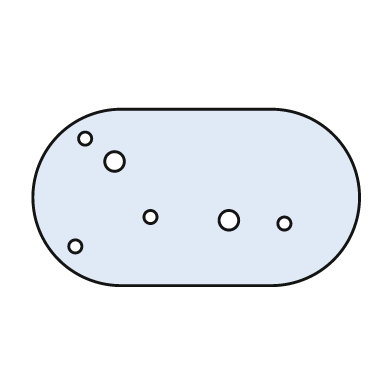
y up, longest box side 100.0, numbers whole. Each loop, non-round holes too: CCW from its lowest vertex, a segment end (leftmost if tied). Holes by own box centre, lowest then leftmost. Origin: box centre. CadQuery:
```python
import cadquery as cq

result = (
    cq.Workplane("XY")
    .moveTo(-23.0, -27.0)
    .lineTo(23.0, -27.0)
    .threePointArc((50.0, 0.0), (23.0, 27.0))
    .lineTo(-23.0, 27.0)
    .threePointArc((-50.0, 0.0), (-23.0, -27.0))
    .close()
    .moveTo(-37.0, -15.0)
    .circle(2.0)
    .moveTo(27.0, -8.0)
    .circle(2.0)
    .moveTo(10.0, -7.0)
    .circle(3.0)
    .moveTo(-14.0, -6.0)
    .circle(2.0)
    .moveTo(-25.0, 11.0)
    .circle(3.0)
    .moveTo(-34.0, 18.0)
    .circle(2.0)
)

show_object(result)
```